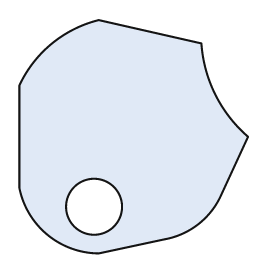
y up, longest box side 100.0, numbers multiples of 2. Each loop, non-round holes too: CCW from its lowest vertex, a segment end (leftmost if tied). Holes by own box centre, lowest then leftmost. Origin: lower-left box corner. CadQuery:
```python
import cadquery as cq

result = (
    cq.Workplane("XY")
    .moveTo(34.0, 0.0)
    .lineTo(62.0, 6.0)
    .threePointArc((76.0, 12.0), (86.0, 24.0))
    .lineTo(98.0, 50.0)
    .threePointArc((84.0, 68.0), (78.0, 90.0))
    .lineTo(34.0, 100.0)
    .threePointArc((14.0, 90.0), (0.0, 72.0))
    .lineTo(0.0, 28.0)
    .threePointArc((12.0, 8.0), (34.0, 0.0))
    .close()
    .moveTo(32.0, 20.0)
    .circle(12.0)
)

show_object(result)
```